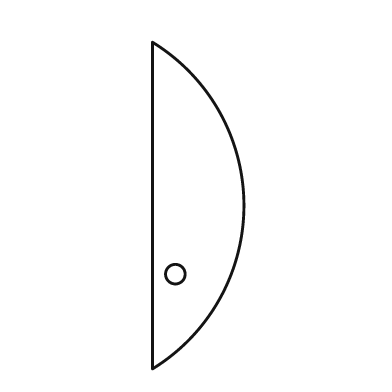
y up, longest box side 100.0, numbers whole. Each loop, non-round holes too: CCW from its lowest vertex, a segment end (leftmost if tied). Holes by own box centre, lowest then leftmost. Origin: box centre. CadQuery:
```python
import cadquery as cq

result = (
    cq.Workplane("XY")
    .moveTo(-14.0, -50.0)
    .threePointArc((14.0, 0.0), (-14.0, 50.0))
    .close()
    .moveTo(-7.0, -21.0)
    .circle(3.0)
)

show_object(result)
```